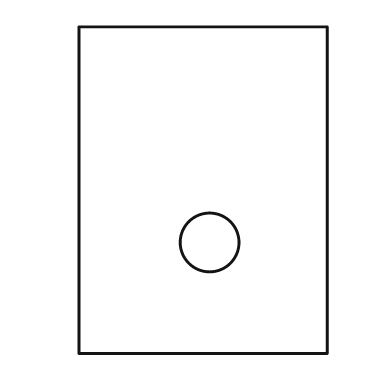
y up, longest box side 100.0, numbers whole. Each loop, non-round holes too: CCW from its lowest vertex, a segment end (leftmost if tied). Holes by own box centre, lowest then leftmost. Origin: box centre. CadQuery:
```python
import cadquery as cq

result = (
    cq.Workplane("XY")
    .moveTo(-38.0, -50.0)
    .lineTo(38.0, -50.0)
    .lineTo(38.0, 50.0)
    .lineTo(-38.0, 50.0)
    .close()
    .moveTo(2.0, -16.0)
    .circle(9.0)
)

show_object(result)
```